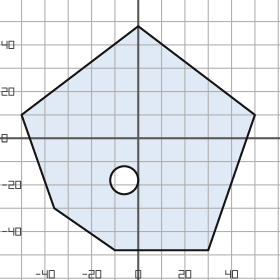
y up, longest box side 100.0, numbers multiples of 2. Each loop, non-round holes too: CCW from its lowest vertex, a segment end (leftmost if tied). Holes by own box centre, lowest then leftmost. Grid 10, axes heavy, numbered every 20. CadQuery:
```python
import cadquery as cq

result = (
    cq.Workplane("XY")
    .moveTo(-10.0, -48.0)
    .lineTo(30.0, -48.0)
    .lineTo(50.0, 10.0)
    .lineTo(0.0, 48.0)
    .lineTo(-50.0, 10.0)
    .lineTo(-36.0, -30.0)
    .close()
    .moveTo(-6.0, -18.0)
    .circle(6.0)
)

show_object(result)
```